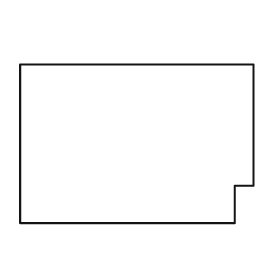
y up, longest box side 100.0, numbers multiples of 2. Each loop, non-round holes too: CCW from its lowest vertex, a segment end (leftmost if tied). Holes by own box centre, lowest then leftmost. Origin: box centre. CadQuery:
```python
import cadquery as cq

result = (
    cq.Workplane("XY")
    .moveTo(-50.0, -34.0)
    .lineTo(42.0, -34.0)
    .lineTo(42.0, -18.0)
    .lineTo(50.0, -18.0)
    .lineTo(50.0, 34.0)
    .lineTo(-50.0, 34.0)
    .close()
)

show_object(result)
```